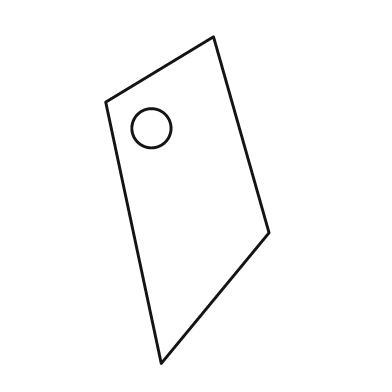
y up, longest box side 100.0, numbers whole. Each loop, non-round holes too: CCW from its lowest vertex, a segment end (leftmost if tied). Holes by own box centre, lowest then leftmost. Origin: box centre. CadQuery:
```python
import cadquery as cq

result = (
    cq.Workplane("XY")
    .moveTo(-8.0, -50.0)
    .lineTo(25.0, -10.0)
    .lineTo(8.0, 50.0)
    .lineTo(-25.0, 30.0)
    .close()
    .moveTo(-11.0, 22.0)
    .circle(6.0)
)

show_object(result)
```